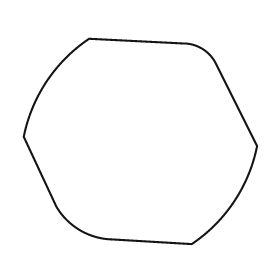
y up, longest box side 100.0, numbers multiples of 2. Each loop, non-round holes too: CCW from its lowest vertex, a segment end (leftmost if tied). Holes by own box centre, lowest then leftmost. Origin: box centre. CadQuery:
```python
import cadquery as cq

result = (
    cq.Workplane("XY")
    .moveTo(22.0, -44.0)
    .threePointArc((40.0, -26.0), (50.0, -2.0))
    .lineTo(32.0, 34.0)
    .threePointArc((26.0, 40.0), (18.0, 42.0))
    .lineTo(-22.0, 44.0)
    .threePointArc((-40.0, 26.0), (-50.0, 2.0))
    .lineTo(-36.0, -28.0)
    .threePointArc((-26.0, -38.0), (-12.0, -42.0))
    .close()
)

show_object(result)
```